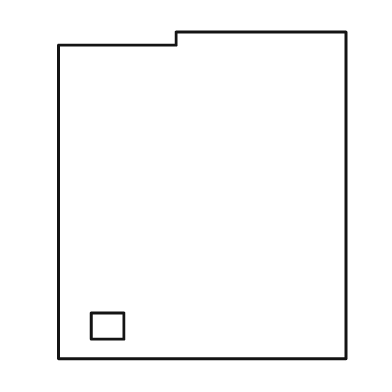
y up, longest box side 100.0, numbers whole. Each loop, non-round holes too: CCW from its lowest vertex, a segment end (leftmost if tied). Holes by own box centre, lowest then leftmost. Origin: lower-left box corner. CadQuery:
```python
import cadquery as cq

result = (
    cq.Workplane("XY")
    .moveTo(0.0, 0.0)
    .lineTo(88.0, 0.0)
    .lineTo(88.0, 100.0)
    .lineTo(36.0, 100.0)
    .lineTo(36.0, 96.0)
    .lineTo(0.0, 96.0)
    .close()
    .moveTo(10.0, 6.0)
    .lineTo(20.0, 6.0)
    .lineTo(20.0, 14.0)
    .lineTo(10.0, 14.0)
    .close()
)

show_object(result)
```